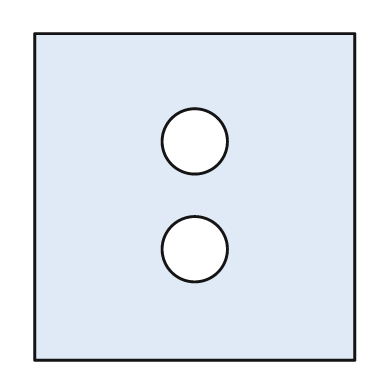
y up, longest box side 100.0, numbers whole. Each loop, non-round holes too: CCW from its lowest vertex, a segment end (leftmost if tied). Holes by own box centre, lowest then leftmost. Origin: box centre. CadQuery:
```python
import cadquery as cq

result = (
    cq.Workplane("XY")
    .moveTo(-49.0, -50.0)
    .lineTo(49.0, -50.0)
    .lineTo(49.0, 50.0)
    .lineTo(-49.0, 50.0)
    .close()
    .moveTo(0.0, -16.0)
    .circle(10.0)
    .moveTo(0.0, 17.0)
    .circle(10.0)
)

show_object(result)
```